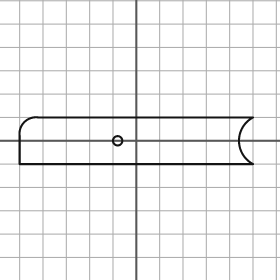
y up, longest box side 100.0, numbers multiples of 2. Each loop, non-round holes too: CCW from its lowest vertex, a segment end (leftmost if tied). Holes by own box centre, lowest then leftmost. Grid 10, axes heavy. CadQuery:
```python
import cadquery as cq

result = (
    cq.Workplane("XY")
    .moveTo(-50.0, -10.0)
    .lineTo(50.0, -10.0)
    .threePointArc((44.0, 0.0), (50.0, 10.0))
    .lineTo(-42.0, 10.0)
    .threePointArc((-48.0, 8.0), (-50.0, 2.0))
    .close()
    .moveTo(-8.0, 0.0)
    .circle(2.0)
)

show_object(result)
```